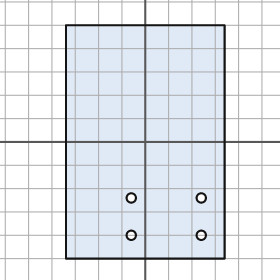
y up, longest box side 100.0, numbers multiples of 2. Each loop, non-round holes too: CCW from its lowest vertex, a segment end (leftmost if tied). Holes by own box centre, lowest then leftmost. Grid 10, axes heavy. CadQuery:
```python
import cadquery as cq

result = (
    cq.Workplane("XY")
    .moveTo(-34.0, -50.0)
    .lineTo(34.0, -50.0)
    .lineTo(34.0, 50.0)
    .lineTo(-34.0, 50.0)
    .close()
    .moveTo(-6.0, -40.0)
    .circle(2.0)
    .moveTo(24.0, -40.0)
    .circle(2.0)
    .moveTo(-6.0, -24.0)
    .circle(2.0)
    .moveTo(24.0, -24.0)
    .circle(2.0)
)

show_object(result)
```